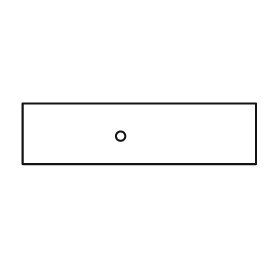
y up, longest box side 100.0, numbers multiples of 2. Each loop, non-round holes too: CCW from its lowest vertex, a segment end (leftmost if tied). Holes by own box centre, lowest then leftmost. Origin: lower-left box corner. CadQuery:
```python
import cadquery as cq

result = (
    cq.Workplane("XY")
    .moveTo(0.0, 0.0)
    .lineTo(100.0, 0.0)
    .lineTo(100.0, 26.0)
    .lineTo(0.0, 26.0)
    .close()
    .moveTo(42.0, 12.0)
    .circle(2.0)
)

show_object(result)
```